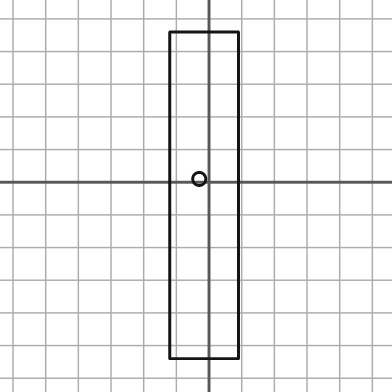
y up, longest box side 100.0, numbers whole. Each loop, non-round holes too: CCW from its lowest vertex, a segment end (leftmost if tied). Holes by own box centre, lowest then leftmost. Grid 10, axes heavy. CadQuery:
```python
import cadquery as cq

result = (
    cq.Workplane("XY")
    .moveTo(-12.0, -54.0)
    .lineTo(9.0, -54.0)
    .lineTo(9.0, 46.0)
    .lineTo(-12.0, 46.0)
    .close()
    .moveTo(-3.0, 1.0)
    .circle(2.0)
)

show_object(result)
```